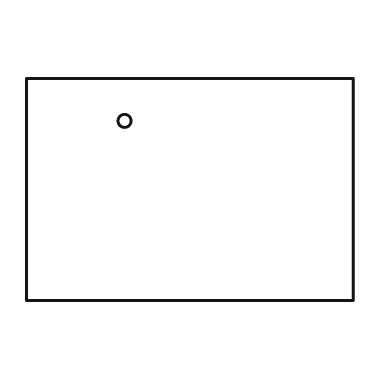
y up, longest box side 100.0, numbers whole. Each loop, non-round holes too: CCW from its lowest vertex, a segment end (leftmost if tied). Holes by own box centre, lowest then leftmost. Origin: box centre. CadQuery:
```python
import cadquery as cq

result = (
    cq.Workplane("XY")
    .moveTo(-50.0, -34.0)
    .lineTo(50.0, -34.0)
    .lineTo(50.0, 34.0)
    .lineTo(-50.0, 34.0)
    .close()
    .moveTo(-20.0, 21.0)
    .circle(2.0)
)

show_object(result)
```